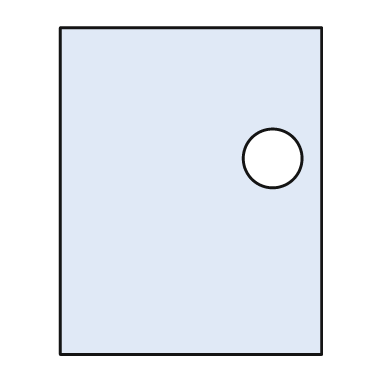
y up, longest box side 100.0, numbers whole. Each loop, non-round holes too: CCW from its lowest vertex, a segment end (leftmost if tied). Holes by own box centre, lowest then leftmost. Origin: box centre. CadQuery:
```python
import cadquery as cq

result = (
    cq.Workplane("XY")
    .moveTo(-40.0, -50.0)
    .lineTo(40.0, -50.0)
    .lineTo(40.0, 50.0)
    .lineTo(-40.0, 50.0)
    .close()
    .moveTo(25.0, 10.0)
    .circle(9.0)
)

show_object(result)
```